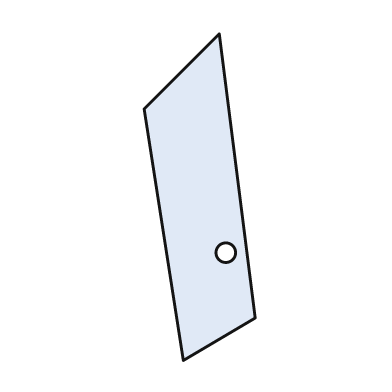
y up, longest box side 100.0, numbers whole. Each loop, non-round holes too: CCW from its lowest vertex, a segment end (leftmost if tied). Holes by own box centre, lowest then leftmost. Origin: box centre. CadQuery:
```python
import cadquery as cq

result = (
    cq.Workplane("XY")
    .moveTo(-5.0, -50.0)
    .lineTo(17.0, -37.0)
    .lineTo(6.0, 50.0)
    .lineTo(-17.0, 27.0)
    .close()
    .moveTo(8.0, -17.0)
    .circle(3.0)
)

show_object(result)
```